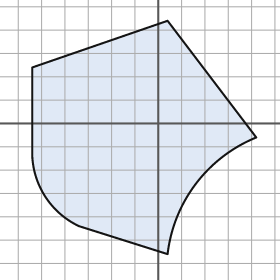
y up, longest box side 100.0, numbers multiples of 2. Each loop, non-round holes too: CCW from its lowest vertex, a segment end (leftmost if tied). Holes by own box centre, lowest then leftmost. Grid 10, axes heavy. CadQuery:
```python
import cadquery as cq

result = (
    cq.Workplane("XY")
    .moveTo(4.0, -56.0)
    .threePointArc((16.0, -26.0), (42.0, -6.0))
    .lineTo(4.0, 44.0)
    .lineTo(-54.0, 24.0)
    .lineTo(-54.0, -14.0)
    .threePointArc((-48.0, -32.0), (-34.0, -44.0))
    .close()
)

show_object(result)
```